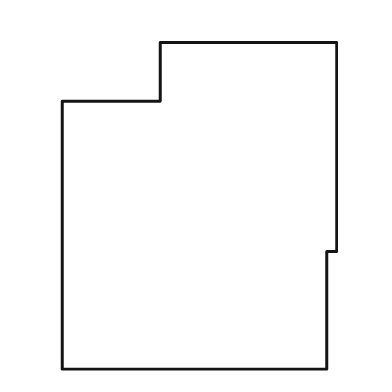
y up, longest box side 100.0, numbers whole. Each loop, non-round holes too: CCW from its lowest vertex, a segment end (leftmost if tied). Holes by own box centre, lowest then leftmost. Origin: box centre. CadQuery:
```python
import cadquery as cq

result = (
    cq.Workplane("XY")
    .moveTo(-42.0, -50.0)
    .lineTo(39.0, -50.0)
    .lineTo(39.0, -14.0)
    .lineTo(42.0, -14.0)
    .lineTo(42.0, 50.0)
    .lineTo(-12.0, 50.0)
    .lineTo(-12.0, 32.0)
    .lineTo(-42.0, 32.0)
    .close()
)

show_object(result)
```